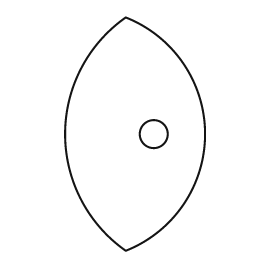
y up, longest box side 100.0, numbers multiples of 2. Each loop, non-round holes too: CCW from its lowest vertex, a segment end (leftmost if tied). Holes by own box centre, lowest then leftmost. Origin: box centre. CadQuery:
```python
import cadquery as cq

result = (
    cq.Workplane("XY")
    .moveTo(-4.0, -50.0)
    .threePointArc((30.0, 0.0), (-4.0, 50.0))
    .threePointArc((-30.0, 0.0), (-4.0, -50.0))
    .close()
    .moveTo(8.0, 0.0)
    .circle(6.0)
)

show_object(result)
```